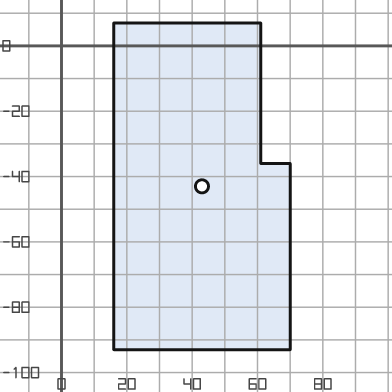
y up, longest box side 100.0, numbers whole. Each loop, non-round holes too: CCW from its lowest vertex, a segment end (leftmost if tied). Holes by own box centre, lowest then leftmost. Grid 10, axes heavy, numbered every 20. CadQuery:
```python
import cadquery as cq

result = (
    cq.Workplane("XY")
    .moveTo(16.0, -93.0)
    .lineTo(70.0, -93.0)
    .lineTo(70.0, -36.0)
    .lineTo(61.0, -36.0)
    .lineTo(61.0, 7.0)
    .lineTo(16.0, 7.0)
    .close()
    .moveTo(43.0, -43.0)
    .circle(2.0)
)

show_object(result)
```